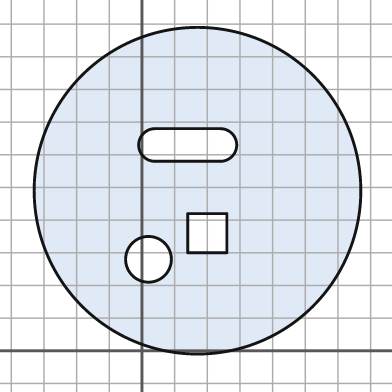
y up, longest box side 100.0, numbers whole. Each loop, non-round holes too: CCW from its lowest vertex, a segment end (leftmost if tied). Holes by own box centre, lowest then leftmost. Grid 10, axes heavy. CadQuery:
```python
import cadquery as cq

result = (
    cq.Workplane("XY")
    .moveTo(17.0, 49.0)
    .circle(50.0)
    .moveTo(2.0, 28.0)
    .circle(7.0)
    .moveTo(14.0, 30.0)
    .lineTo(26.0, 30.0)
    .lineTo(26.0, 42.0)
    .lineTo(14.0, 42.0)
    .close()
    .moveTo(4.0, 58.0)
    .lineTo(24.0, 58.0)
    .threePointArc((29.0, 63.0), (24.0, 68.0))
    .lineTo(4.0, 68.0)
    .threePointArc((-1.0, 63.0), (4.0, 58.0))
    .close()
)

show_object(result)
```